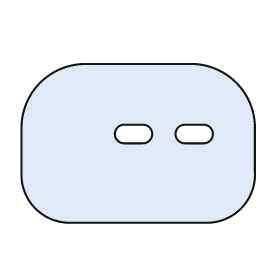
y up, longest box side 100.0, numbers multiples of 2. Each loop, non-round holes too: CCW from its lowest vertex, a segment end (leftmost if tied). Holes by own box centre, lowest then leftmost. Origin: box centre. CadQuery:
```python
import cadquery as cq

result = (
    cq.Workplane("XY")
    .moveTo(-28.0, -34.0)
    .lineTo(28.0, -34.0)
    .threePointArc((44.0, -28.0), (50.0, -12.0))
    .lineTo(50.0, 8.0)
    .threePointArc((42.0, 26.0), (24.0, 34.0))
    .lineTo(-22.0, 34.0)
    .threePointArc((-42.0, 26.0), (-50.0, 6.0))
    .lineTo(-50.0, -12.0)
    .threePointArc((-44.0, -28.0), (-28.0, -34.0))
    .close()
    .moveTo(-6.0, 0.0)
    .lineTo(2.0, 0.0)
    .threePointArc((6.0, 4.0), (2.0, 8.0))
    .lineTo(-6.0, 8.0)
    .threePointArc((-10.0, 4.0), (-6.0, 0.0))
    .close()
    .moveTo(20.0, 0.0)
    .lineTo(28.0, 0.0)
    .threePointArc((32.0, 4.0), (28.0, 8.0))
    .lineTo(20.0, 8.0)
    .threePointArc((16.0, 4.0), (20.0, 0.0))
    .close()
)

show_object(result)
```